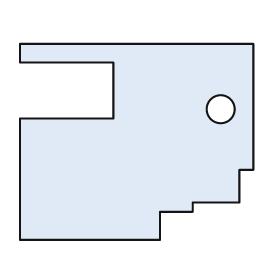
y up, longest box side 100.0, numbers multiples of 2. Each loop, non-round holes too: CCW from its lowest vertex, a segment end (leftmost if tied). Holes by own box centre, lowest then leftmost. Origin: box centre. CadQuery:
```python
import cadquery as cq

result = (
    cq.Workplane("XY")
    .moveTo(-50.0, -42.0)
    .lineTo(10.0, -42.0)
    .lineTo(10.0, -30.0)
    .lineTo(24.0, -30.0)
    .lineTo(24.0, -26.0)
    .lineTo(44.0, -26.0)
    .lineTo(44.0, -12.0)
    .lineTo(50.0, -12.0)
    .lineTo(50.0, 42.0)
    .lineTo(-50.0, 42.0)
    .lineTo(-50.0, 34.0)
    .lineTo(-10.0, 34.0)
    .lineTo(-10.0, 10.0)
    .lineTo(-50.0, 10.0)
    .close()
    .moveTo(36.0, 14.0)
    .circle(6.0)
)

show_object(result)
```